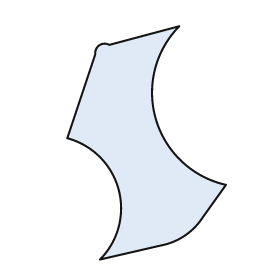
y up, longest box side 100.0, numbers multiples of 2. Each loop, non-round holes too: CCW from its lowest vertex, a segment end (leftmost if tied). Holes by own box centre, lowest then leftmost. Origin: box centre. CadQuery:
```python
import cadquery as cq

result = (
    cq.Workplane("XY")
    .moveTo(-20.0, -50.0)
    .lineTo(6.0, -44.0)
    .threePointArc((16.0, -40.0), (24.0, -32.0))
    .lineTo(34.0, -18.0)
    .threePointArc((4.0, 10.0), (14.0, 50.0))
    .lineTo(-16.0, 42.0)
    .threePointArc((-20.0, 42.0), (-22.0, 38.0))
    .lineTo(-34.0, 2.0)
    .threePointArc((-12.0, -20.0), (-20.0, -50.0))
    .close()
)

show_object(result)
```